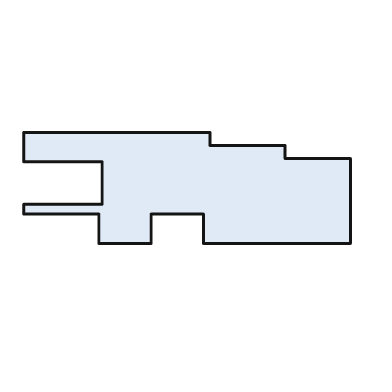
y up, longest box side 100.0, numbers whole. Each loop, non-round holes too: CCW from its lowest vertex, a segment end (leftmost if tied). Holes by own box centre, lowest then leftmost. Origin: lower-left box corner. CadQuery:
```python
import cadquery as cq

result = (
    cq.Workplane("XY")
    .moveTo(23.0, 0.0)
    .lineTo(39.0, 0.0)
    .lineTo(39.0, 9.0)
    .lineTo(55.0, 9.0)
    .lineTo(55.0, 0.0)
    .lineTo(100.0, 0.0)
    .lineTo(100.0, 26.0)
    .lineTo(80.0, 26.0)
    .lineTo(80.0, 30.0)
    .lineTo(57.0, 30.0)
    .lineTo(57.0, 34.0)
    .lineTo(0.0, 34.0)
    .lineTo(0.0, 25.0)
    .lineTo(24.0, 25.0)
    .lineTo(24.0, 12.0)
    .lineTo(0.0, 12.0)
    .lineTo(0.0, 9.0)
    .lineTo(23.0, 9.0)
    .close()
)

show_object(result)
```